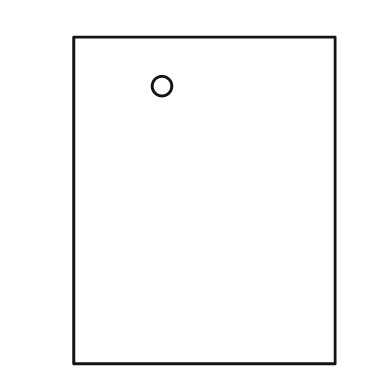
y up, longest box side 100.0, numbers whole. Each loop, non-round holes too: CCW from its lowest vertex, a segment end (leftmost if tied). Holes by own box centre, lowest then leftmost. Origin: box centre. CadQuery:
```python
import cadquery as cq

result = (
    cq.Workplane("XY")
    .moveTo(-40.0, -50.0)
    .lineTo(40.0, -50.0)
    .lineTo(40.0, 50.0)
    .lineTo(-40.0, 50.0)
    .close()
    .moveTo(-13.0, 35.0)
    .circle(3.0)
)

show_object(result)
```